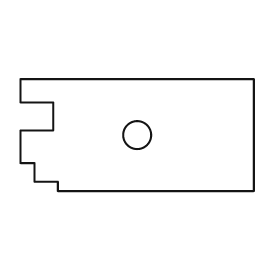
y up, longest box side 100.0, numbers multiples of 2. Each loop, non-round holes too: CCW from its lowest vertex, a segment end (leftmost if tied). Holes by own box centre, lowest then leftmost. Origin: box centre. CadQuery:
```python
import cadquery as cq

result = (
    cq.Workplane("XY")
    .moveTo(-34.0, -24.0)
    .lineTo(50.0, -24.0)
    .lineTo(50.0, 24.0)
    .lineTo(-50.0, 24.0)
    .lineTo(-50.0, 14.0)
    .lineTo(-36.0, 14.0)
    .lineTo(-36.0, 2.0)
    .lineTo(-50.0, 2.0)
    .lineTo(-50.0, -12.0)
    .lineTo(-44.0, -12.0)
    .lineTo(-44.0, -20.0)
    .lineTo(-34.0, -20.0)
    .close()
    .moveTo(0.0, 0.0)
    .circle(6.0)
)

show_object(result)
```